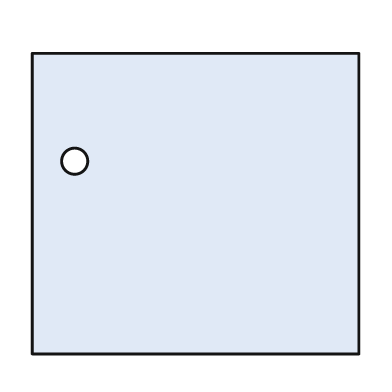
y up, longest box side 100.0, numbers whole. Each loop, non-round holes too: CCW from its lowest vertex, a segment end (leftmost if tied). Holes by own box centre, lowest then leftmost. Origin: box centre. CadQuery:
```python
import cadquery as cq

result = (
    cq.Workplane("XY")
    .moveTo(-50.0, -46.0)
    .lineTo(50.0, -46.0)
    .lineTo(50.0, 46.0)
    .lineTo(-50.0, 46.0)
    .close()
    .moveTo(-37.0, 13.0)
    .circle(4.0)
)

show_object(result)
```